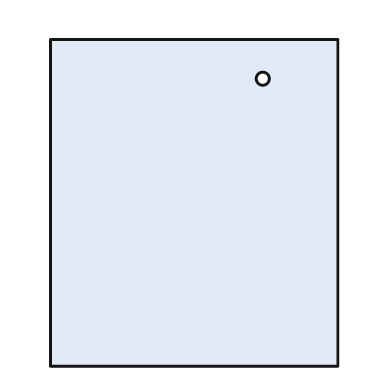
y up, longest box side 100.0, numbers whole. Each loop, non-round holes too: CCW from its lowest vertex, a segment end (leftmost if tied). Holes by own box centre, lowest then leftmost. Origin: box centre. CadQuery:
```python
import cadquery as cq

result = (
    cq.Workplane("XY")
    .moveTo(-44.0, -50.0)
    .lineTo(44.0, -50.0)
    .lineTo(44.0, 50.0)
    .lineTo(-44.0, 50.0)
    .close()
    .moveTo(21.0, 38.0)
    .circle(2.0)
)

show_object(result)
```